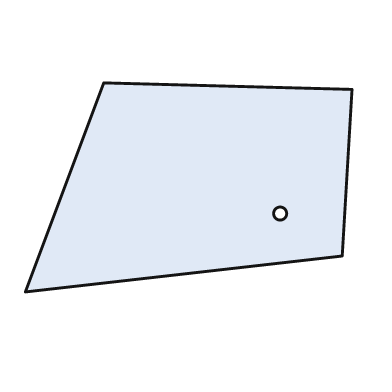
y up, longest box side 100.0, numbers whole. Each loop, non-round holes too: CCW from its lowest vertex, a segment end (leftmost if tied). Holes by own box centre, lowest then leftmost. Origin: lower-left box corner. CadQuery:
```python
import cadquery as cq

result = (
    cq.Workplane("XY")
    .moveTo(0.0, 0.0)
    .lineTo(97.0, 11.0)
    .lineTo(100.0, 62.0)
    .lineTo(24.0, 64.0)
    .close()
    .moveTo(78.0, 24.0)
    .circle(2.0)
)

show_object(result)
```